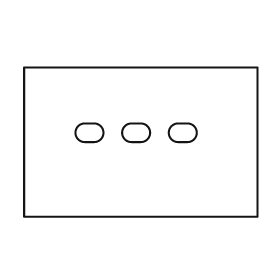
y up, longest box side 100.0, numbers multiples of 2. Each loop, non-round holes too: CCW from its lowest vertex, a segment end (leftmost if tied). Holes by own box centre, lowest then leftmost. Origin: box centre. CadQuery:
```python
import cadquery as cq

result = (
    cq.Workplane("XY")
    .moveTo(-50.0, -32.0)
    .lineTo(50.0, -32.0)
    .lineTo(50.0, 32.0)
    .lineTo(-50.0, 32.0)
    .close()
    .moveTo(-24.0, 0.0)
    .lineTo(-20.0, 0.0)
    .threePointArc((-16.0, 4.0), (-20.0, 8.0))
    .lineTo(-24.0, 8.0)
    .threePointArc((-28.0, 4.0), (-24.0, 0.0))
    .close()
    .moveTo(-4.0, 0.0)
    .lineTo(0.0, 0.0)
    .threePointArc((4.0, 4.0), (0.0, 8.0))
    .lineTo(-4.0, 8.0)
    .threePointArc((-8.0, 4.0), (-4.0, 0.0))
    .close()
    .moveTo(16.0, 0.0)
    .lineTo(20.0, 0.0)
    .threePointArc((24.0, 4.0), (20.0, 8.0))
    .lineTo(16.0, 8.0)
    .threePointArc((12.0, 4.0), (16.0, 0.0))
    .close()
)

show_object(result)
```